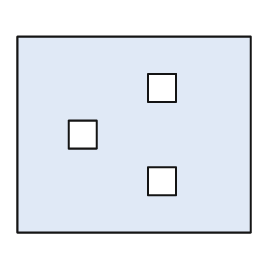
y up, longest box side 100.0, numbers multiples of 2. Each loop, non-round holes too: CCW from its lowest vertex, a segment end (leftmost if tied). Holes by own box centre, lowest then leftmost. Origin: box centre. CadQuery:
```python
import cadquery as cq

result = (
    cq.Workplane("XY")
    .moveTo(-50.0, -42.0)
    .lineTo(50.0, -42.0)
    .lineTo(50.0, 42.0)
    .lineTo(-50.0, 42.0)
    .close()
    .moveTo(6.0, -26.0)
    .lineTo(18.0, -26.0)
    .lineTo(18.0, -14.0)
    .lineTo(6.0, -14.0)
    .close()
    .moveTo(-28.0, -6.0)
    .lineTo(-16.0, -6.0)
    .lineTo(-16.0, 6.0)
    .lineTo(-28.0, 6.0)
    .close()
    .moveTo(6.0, 14.0)
    .lineTo(18.0, 14.0)
    .lineTo(18.0, 26.0)
    .lineTo(6.0, 26.0)
    .close()
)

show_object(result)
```